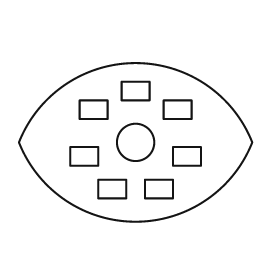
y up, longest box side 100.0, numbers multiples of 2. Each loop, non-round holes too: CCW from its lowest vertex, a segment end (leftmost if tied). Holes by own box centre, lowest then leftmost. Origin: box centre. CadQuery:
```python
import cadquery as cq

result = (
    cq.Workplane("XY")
    .moveTo(-50.0, 0.0)
    .threePointArc((0.0, -34.0), (50.0, 0.0))
    .threePointArc((0.0, 34.0), (-50.0, 0.0))
    .close()
    .moveTo(-16.0, -24.0)
    .lineTo(-4.0, -24.0)
    .lineTo(-4.0, -16.0)
    .lineTo(-16.0, -16.0)
    .close()
    .moveTo(4.0, -24.0)
    .lineTo(16.0, -24.0)
    .lineTo(16.0, -16.0)
    .lineTo(4.0, -16.0)
    .close()
    .moveTo(-28.0, -10.0)
    .lineTo(-16.0, -10.0)
    .lineTo(-16.0, -2.0)
    .lineTo(-28.0, -2.0)
    .close()
    .moveTo(16.0, -10.0)
    .lineTo(28.0, -10.0)
    .lineTo(28.0, -2.0)
    .lineTo(16.0, -2.0)
    .close()
    .moveTo(0.0, 0.0)
    .circle(8.0)
    .moveTo(-24.0, 10.0)
    .lineTo(-12.0, 10.0)
    .lineTo(-12.0, 18.0)
    .lineTo(-24.0, 18.0)
    .close()
    .moveTo(12.0, 10.0)
    .lineTo(24.0, 10.0)
    .lineTo(24.0, 18.0)
    .lineTo(12.0, 18.0)
    .close()
    .moveTo(-6.0, 18.0)
    .lineTo(6.0, 18.0)
    .lineTo(6.0, 26.0)
    .lineTo(-6.0, 26.0)
    .close()
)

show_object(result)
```